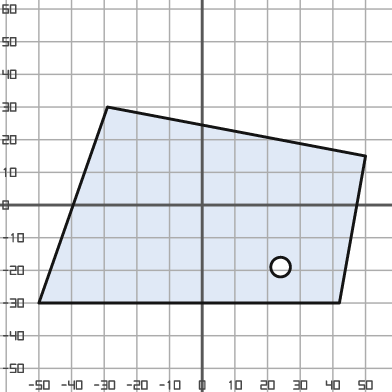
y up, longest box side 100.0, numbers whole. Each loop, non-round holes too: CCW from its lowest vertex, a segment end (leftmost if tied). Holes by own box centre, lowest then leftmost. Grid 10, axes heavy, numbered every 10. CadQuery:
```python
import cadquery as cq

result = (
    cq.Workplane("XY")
    .moveTo(-50.0, -30.0)
    .lineTo(42.0, -30.0)
    .lineTo(50.0, 15.0)
    .lineTo(-29.0, 30.0)
    .close()
    .moveTo(24.0, -19.0)
    .circle(3.0)
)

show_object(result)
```